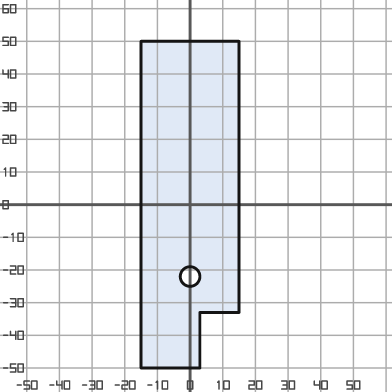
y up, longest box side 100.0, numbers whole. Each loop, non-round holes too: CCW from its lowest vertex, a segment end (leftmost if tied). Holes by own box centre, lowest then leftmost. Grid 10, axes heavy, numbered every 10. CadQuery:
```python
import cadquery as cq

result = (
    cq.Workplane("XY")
    .moveTo(-15.0, -50.0)
    .lineTo(3.0, -50.0)
    .lineTo(3.0, -33.0)
    .lineTo(15.0, -33.0)
    .lineTo(15.0, 50.0)
    .lineTo(-15.0, 50.0)
    .close()
    .moveTo(0.0, -22.0)
    .circle(3.0)
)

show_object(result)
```